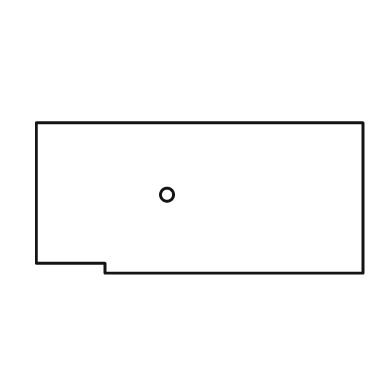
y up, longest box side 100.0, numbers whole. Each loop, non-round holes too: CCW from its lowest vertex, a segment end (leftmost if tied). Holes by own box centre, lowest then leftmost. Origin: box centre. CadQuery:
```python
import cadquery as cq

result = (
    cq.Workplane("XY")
    .moveTo(-29.0, -23.0)
    .lineTo(50.0, -23.0)
    .lineTo(50.0, 23.0)
    .lineTo(-50.0, 23.0)
    .lineTo(-50.0, -20.0)
    .lineTo(-29.0, -20.0)
    .close()
    .moveTo(-10.0, 1.0)
    .circle(2.0)
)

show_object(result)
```